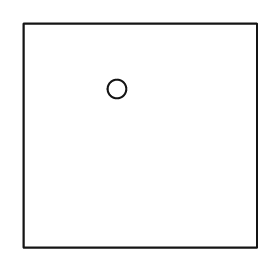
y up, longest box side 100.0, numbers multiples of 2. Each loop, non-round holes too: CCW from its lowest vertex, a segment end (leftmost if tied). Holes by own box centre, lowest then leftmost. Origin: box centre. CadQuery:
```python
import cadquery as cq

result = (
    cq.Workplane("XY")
    .moveTo(-50.0, -48.0)
    .lineTo(50.0, -48.0)
    .lineTo(50.0, 48.0)
    .lineTo(-50.0, 48.0)
    .close()
    .moveTo(-10.0, 20.0)
    .circle(4.0)
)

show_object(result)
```